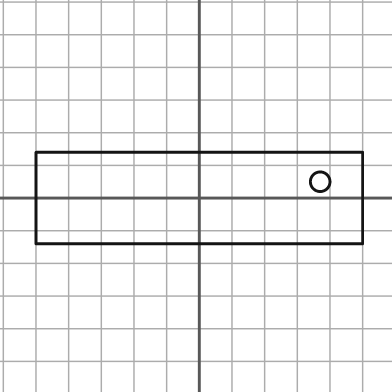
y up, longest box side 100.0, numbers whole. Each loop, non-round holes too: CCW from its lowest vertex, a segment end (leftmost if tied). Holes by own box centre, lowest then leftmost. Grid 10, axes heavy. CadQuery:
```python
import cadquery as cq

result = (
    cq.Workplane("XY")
    .moveTo(-50.0, -14.0)
    .lineTo(50.0, -14.0)
    .lineTo(50.0, 14.0)
    .lineTo(-50.0, 14.0)
    .close()
    .moveTo(37.0, 5.0)
    .circle(3.0)
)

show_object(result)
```